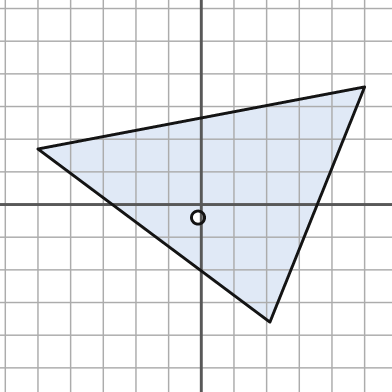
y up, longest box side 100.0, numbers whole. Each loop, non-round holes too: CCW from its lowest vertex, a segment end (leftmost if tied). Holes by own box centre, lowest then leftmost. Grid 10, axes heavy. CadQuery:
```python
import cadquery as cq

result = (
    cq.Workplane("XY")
    .moveTo(21.0, -36.0)
    .lineTo(50.0, 36.0)
    .lineTo(-50.0, 17.0)
    .close()
    .moveTo(-1.0, -4.0)
    .circle(2.0)
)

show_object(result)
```